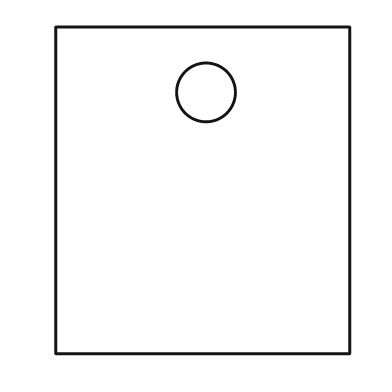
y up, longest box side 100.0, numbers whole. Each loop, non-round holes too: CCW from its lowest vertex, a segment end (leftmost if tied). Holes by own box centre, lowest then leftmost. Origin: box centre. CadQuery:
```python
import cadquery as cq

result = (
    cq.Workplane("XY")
    .moveTo(-45.0, -50.0)
    .lineTo(45.0, -50.0)
    .lineTo(45.0, 50.0)
    .lineTo(-45.0, 50.0)
    .close()
    .moveTo(1.0, 30.0)
    .circle(9.0)
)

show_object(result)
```